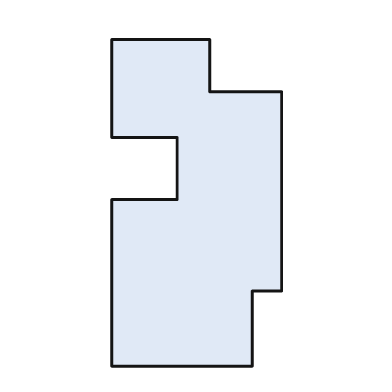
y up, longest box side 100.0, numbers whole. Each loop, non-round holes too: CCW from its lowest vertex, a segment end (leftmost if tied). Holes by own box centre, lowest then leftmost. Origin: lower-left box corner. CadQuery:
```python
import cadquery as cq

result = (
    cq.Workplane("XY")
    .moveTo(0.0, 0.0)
    .lineTo(43.0, 0.0)
    .lineTo(43.0, 23.0)
    .lineTo(52.0, 23.0)
    .lineTo(52.0, 84.0)
    .lineTo(30.0, 84.0)
    .lineTo(30.0, 100.0)
    .lineTo(0.0, 100.0)
    .lineTo(0.0, 70.0)
    .lineTo(20.0, 70.0)
    .lineTo(20.0, 51.0)
    .lineTo(0.0, 51.0)
    .close()
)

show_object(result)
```